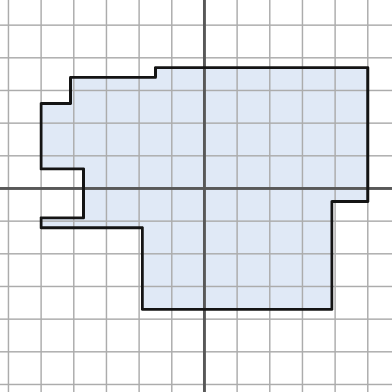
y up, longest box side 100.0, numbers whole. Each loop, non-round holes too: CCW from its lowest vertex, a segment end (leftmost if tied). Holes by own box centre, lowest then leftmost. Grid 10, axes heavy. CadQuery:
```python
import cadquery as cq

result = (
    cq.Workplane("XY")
    .moveTo(-19.0, -37.0)
    .lineTo(39.0, -37.0)
    .lineTo(39.0, -4.0)
    .lineTo(50.0, -4.0)
    .lineTo(50.0, 37.0)
    .lineTo(-15.0, 37.0)
    .lineTo(-15.0, 34.0)
    .lineTo(-41.0, 34.0)
    .lineTo(-41.0, 26.0)
    .lineTo(-50.0, 26.0)
    .lineTo(-50.0, 6.0)
    .lineTo(-37.0, 6.0)
    .lineTo(-37.0, -9.0)
    .lineTo(-50.0, -9.0)
    .lineTo(-50.0, -12.0)
    .lineTo(-19.0, -12.0)
    .close()
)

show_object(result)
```